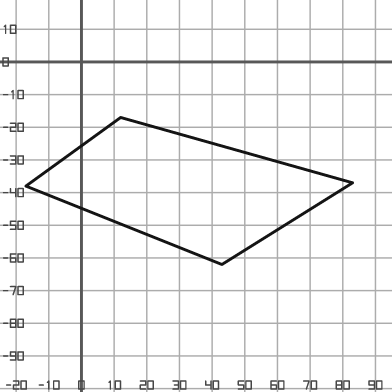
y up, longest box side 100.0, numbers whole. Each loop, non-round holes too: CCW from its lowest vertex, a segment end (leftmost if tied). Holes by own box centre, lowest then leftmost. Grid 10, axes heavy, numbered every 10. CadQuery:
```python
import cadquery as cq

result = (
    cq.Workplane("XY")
    .moveTo(43.0, -62.0)
    .lineTo(83.0, -37.0)
    .lineTo(12.0, -17.0)
    .lineTo(-17.0, -38.0)
    .close()
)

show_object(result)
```